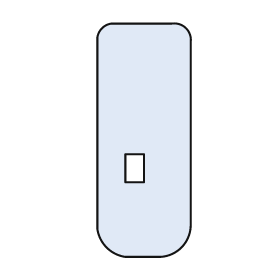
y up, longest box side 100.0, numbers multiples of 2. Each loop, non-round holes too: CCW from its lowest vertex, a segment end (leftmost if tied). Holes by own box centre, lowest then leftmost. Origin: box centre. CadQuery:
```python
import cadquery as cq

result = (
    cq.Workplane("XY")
    .moveTo(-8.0, -50.0)
    .lineTo(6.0, -50.0)
    .threePointArc((16.0, -46.0), (20.0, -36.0))
    .lineTo(20.0, 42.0)
    .threePointArc((18.0, 48.0), (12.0, 50.0))
    .lineTo(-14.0, 50.0)
    .threePointArc((-18.0, 48.0), (-20.0, 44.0))
    .lineTo(-20.0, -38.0)
    .threePointArc((-16.0, -46.0), (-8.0, -50.0))
    .close()
    .moveTo(-8.0, -18.0)
    .lineTo(0.0, -18.0)
    .lineTo(0.0, -6.0)
    .lineTo(-8.0, -6.0)
    .close()
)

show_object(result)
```